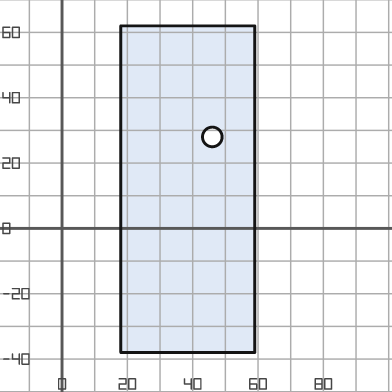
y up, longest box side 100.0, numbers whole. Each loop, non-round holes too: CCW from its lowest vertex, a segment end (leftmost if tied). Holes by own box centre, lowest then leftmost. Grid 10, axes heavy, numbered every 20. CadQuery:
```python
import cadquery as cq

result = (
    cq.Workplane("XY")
    .moveTo(18.0, -38.0)
    .lineTo(59.0, -38.0)
    .lineTo(59.0, 62.0)
    .lineTo(18.0, 62.0)
    .close()
    .moveTo(46.0, 28.0)
    .circle(3.0)
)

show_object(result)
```